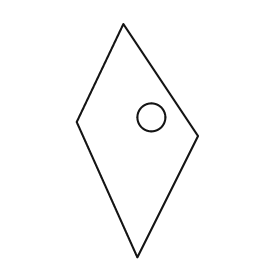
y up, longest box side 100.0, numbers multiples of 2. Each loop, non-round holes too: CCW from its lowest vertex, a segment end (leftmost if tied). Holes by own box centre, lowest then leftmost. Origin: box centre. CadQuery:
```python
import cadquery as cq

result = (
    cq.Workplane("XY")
    .moveTo(0.0, -50.0)
    .lineTo(26.0, 2.0)
    .lineTo(-6.0, 50.0)
    .lineTo(-26.0, 8.0)
    .close()
    .moveTo(6.0, 10.0)
    .circle(6.0)
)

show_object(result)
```